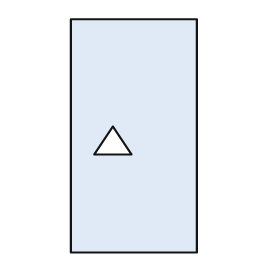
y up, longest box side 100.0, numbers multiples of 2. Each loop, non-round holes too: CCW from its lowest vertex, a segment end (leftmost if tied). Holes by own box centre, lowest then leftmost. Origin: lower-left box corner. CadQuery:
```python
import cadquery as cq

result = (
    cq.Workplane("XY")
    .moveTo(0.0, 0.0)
    .lineTo(54.0, 0.0)
    .lineTo(54.0, 100.0)
    .lineTo(0.0, 100.0)
    .close()
    .moveTo(10.0, 42.0)
    .lineTo(26.0, 42.0)
    .lineTo(18.0, 54.0)
    .close()
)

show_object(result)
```